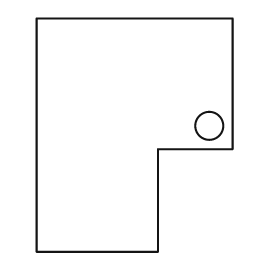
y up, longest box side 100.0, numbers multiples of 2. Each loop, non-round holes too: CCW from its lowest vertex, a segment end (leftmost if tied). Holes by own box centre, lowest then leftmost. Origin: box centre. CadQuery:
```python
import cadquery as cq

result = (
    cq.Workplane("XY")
    .moveTo(-42.0, -50.0)
    .lineTo(10.0, -50.0)
    .lineTo(10.0, -6.0)
    .lineTo(42.0, -6.0)
    .lineTo(42.0, 50.0)
    .lineTo(-42.0, 50.0)
    .close()
    .moveTo(32.0, 4.0)
    .circle(6.0)
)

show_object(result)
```